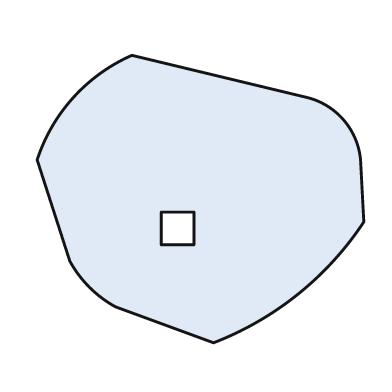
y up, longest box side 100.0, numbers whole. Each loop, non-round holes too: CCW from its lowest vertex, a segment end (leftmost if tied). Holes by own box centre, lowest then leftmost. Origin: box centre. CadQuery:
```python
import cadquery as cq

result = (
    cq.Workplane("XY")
    .moveTo(4.0, -44.0)
    .threePointArc((30.0, -29.0), (50.0, -7.0))
    .lineTo(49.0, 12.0)
    .threePointArc((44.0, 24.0), (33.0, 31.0))
    .lineTo(-21.0, 44.0)
    .threePointArc((-39.0, 31.0), (-50.0, 12.0))
    .lineTo(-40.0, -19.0)
    .threePointArc((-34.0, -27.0), (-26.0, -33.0))
    .close()
    .moveTo(-12.0, -14.0)
    .lineTo(-2.0, -14.0)
    .lineTo(-2.0, -4.0)
    .lineTo(-12.0, -4.0)
    .close()
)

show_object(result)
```